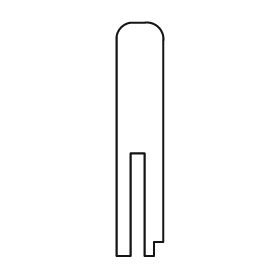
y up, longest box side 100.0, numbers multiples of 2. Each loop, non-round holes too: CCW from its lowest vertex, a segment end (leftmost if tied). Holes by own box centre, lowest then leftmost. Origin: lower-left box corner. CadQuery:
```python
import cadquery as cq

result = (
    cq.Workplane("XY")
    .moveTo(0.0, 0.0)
    .lineTo(6.0, 0.0)
    .lineTo(6.0, 44.0)
    .lineTo(12.0, 44.0)
    .lineTo(12.0, 0.0)
    .lineTo(16.0, 0.0)
    .lineTo(16.0, 6.0)
    .lineTo(20.0, 6.0)
    .lineTo(20.0, 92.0)
    .threePointArc((18.0, 98.0), (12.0, 100.0))
    .lineTo(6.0, 100.0)
    .threePointArc((2.0, 98.0), (0.0, 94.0))
    .close()
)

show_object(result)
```